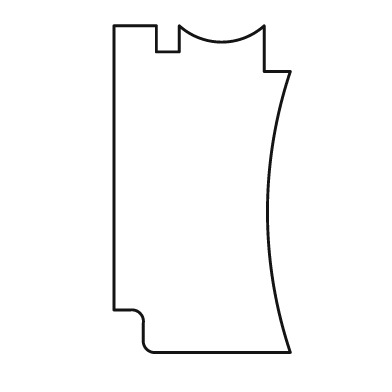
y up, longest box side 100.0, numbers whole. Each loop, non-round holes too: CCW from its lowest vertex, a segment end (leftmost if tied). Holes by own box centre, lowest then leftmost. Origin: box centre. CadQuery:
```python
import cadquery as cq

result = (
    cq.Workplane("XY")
    .moveTo(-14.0, -50.0)
    .lineTo(27.0, -50.0)
    .threePointArc((20.0, -7.0), (27.0, 36.0))
    .lineTo(19.0, 36.0)
    .lineTo(19.0, 50.0)
    .threePointArc((6.0, 45.0), (-7.0, 50.0))
    .lineTo(-7.0, 42.0)
    .lineTo(-14.0, 42.0)
    .lineTo(-14.0, 50.0)
    .lineTo(-27.0, 50.0)
    .lineTo(-27.0, -37.0)
    .lineTo(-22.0, -37.0)
    .threePointArc((-19.0, -38.0), (-18.0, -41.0))
    .lineTo(-18.0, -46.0)
    .threePointArc((-17.0, -49.0), (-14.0, -50.0))
    .close()
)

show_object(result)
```